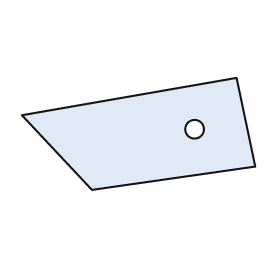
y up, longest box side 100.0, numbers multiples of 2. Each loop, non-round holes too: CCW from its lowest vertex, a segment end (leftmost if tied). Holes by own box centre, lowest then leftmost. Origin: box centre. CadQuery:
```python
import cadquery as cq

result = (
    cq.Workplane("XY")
    .moveTo(-20.0, -24.0)
    .lineTo(50.0, -14.0)
    .lineTo(42.0, 24.0)
    .lineTo(-50.0, 8.0)
    .close()
    .moveTo(24.0, 2.0)
    .circle(4.0)
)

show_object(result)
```